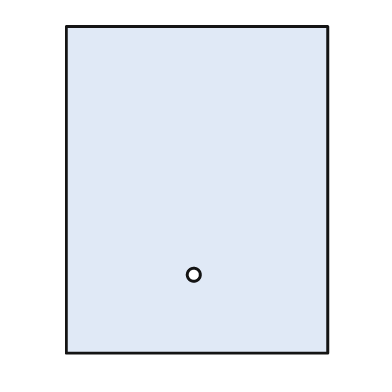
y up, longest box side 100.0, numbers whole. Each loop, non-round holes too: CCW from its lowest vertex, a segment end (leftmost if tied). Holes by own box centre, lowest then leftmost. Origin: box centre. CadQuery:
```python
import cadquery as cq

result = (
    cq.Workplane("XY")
    .moveTo(-40.0, -50.0)
    .lineTo(40.0, -50.0)
    .lineTo(40.0, 50.0)
    .lineTo(-40.0, 50.0)
    .close()
    .moveTo(-1.0, -26.0)
    .circle(2.0)
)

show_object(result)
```